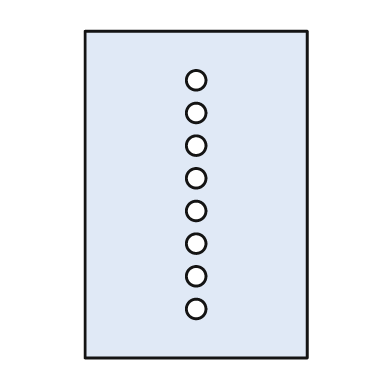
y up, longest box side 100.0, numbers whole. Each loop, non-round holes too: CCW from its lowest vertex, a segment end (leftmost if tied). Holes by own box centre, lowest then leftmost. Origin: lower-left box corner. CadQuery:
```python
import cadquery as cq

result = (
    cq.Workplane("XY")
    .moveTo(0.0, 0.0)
    .lineTo(68.0, 0.0)
    .lineTo(68.0, 100.0)
    .lineTo(0.0, 100.0)
    .close()
    .moveTo(34.0, 15.0)
    .circle(3.0)
    .moveTo(34.0, 25.0)
    .circle(3.0)
    .moveTo(34.0, 35.0)
    .circle(3.0)
    .moveTo(34.0, 45.0)
    .circle(3.0)
    .moveTo(34.0, 55.0)
    .circle(3.0)
    .moveTo(34.0, 65.0)
    .circle(3.0)
    .moveTo(34.0, 75.0)
    .circle(3.0)
    .moveTo(34.0, 85.0)
    .circle(3.0)
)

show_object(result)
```